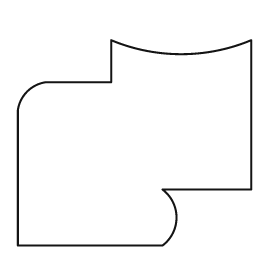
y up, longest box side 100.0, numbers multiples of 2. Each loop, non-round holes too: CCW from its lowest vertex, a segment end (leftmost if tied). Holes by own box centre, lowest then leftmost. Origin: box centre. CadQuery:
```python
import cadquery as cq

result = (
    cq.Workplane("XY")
    .moveTo(-50.0, -44.0)
    .lineTo(12.0, -44.0)
    .threePointArc((18.0, -32.0), (12.0, -20.0))
    .lineTo(50.0, -20.0)
    .lineTo(50.0, 44.0)
    .threePointArc((20.0, 38.0), (-10.0, 44.0))
    .lineTo(-10.0, 26.0)
    .lineTo(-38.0, 26.0)
    .threePointArc((-46.0, 22.0), (-50.0, 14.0))
    .close()
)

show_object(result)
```